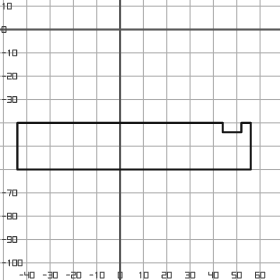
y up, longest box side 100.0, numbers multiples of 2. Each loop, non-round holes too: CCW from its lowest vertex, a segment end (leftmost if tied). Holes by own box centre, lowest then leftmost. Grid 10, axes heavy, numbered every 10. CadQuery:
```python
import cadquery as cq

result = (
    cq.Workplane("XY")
    .moveTo(-44.0, -60.0)
    .lineTo(56.0, -60.0)
    .lineTo(56.0, -40.0)
    .lineTo(52.0, -40.0)
    .lineTo(52.0, -44.0)
    .lineTo(44.0, -44.0)
    .lineTo(44.0, -40.0)
    .lineTo(-44.0, -40.0)
    .close()
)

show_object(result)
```